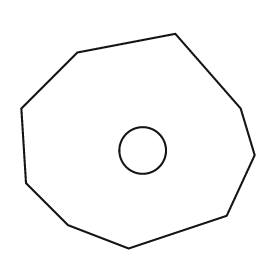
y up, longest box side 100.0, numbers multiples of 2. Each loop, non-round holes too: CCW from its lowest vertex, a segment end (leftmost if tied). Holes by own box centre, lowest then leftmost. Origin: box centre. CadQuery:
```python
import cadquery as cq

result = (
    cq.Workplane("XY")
    .moveTo(-4.0, -46.0)
    .lineTo(38.0, -32.0)
    .lineTo(50.0, -6.0)
    .lineTo(44.0, 14.0)
    .lineTo(16.0, 46.0)
    .lineTo(-26.0, 38.0)
    .lineTo(-50.0, 14.0)
    .lineTo(-48.0, -18.0)
    .lineTo(-30.0, -36.0)
    .close()
    .moveTo(2.0, -4.0)
    .circle(10.0)
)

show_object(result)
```